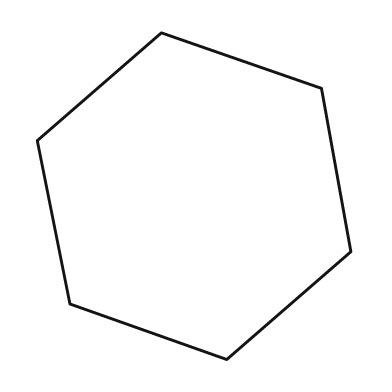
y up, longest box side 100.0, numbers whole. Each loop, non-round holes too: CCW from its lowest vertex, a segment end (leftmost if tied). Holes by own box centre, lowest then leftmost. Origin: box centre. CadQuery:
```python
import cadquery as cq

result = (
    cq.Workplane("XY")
    .moveTo(10.0, -50.0)
    .lineTo(48.0, -17.0)
    .lineTo(39.0, 33.0)
    .lineTo(-10.0, 50.0)
    .lineTo(-48.0, 17.0)
    .lineTo(-38.0, -33.0)
    .close()
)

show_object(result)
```